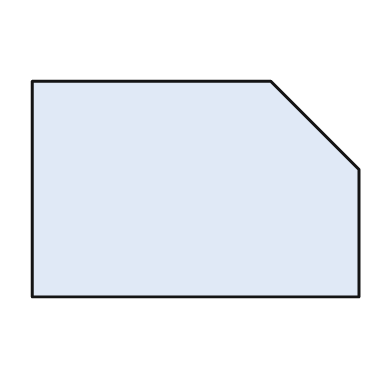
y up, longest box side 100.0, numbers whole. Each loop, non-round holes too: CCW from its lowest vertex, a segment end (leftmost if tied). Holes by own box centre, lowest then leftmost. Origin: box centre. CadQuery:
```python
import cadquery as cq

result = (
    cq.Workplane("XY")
    .moveTo(-50.0, -33.0)
    .lineTo(50.0, -33.0)
    .lineTo(50.0, 6.0)
    .lineTo(23.0, 33.0)
    .lineTo(-50.0, 33.0)
    .close()
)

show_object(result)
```